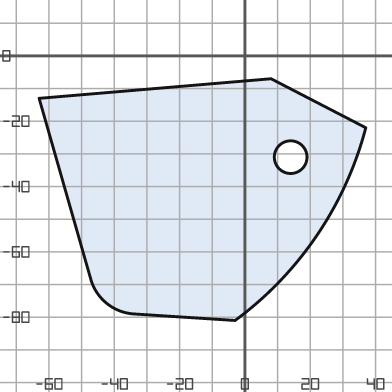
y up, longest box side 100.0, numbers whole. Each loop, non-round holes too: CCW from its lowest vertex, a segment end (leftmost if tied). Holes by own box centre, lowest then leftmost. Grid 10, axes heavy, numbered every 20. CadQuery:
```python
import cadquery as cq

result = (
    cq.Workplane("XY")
    .moveTo(-3.0, -81.0)
    .threePointArc((22.0, -55.0), (37.0, -22.0))
    .lineTo(8.0, -7.0)
    .lineTo(-63.0, -13.0)
    .lineTo(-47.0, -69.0)
    .threePointArc((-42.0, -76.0), (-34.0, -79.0))
    .close()
    .moveTo(14.0, -31.0)
    .circle(5.0)
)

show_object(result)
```